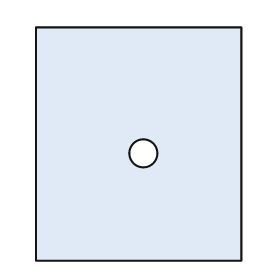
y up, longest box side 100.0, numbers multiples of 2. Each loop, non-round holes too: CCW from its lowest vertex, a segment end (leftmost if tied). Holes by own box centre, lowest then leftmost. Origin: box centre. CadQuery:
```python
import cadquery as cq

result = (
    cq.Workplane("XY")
    .moveTo(-44.0, -50.0)
    .lineTo(44.0, -50.0)
    .lineTo(44.0, 50.0)
    .lineTo(-44.0, 50.0)
    .close()
    .moveTo(2.0, -4.0)
    .circle(6.0)
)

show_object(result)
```